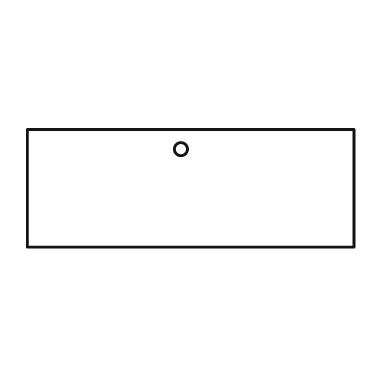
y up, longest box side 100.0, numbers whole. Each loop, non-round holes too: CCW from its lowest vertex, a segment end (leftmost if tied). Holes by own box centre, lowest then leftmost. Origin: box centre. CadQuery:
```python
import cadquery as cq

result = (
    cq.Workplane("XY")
    .moveTo(-50.0, -18.0)
    .lineTo(50.0, -18.0)
    .lineTo(50.0, 18.0)
    .lineTo(-50.0, 18.0)
    .close()
    .moveTo(-3.0, 12.0)
    .circle(2.0)
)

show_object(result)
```